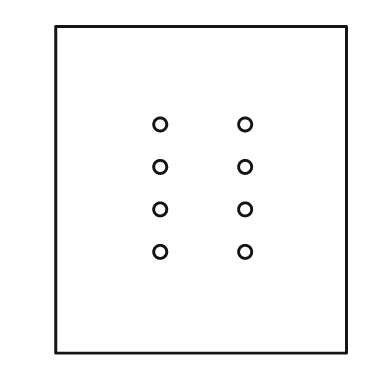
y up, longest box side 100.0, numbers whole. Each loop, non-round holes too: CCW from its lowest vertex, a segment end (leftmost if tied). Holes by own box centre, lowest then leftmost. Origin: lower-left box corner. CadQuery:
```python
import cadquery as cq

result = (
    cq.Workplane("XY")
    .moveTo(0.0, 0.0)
    .lineTo(89.0, 0.0)
    .lineTo(89.0, 100.0)
    .lineTo(0.0, 100.0)
    .close()
    .moveTo(32.0, 31.0)
    .circle(2.0)
    .moveTo(58.0, 31.0)
    .circle(2.0)
    .moveTo(32.0, 44.0)
    .circle(2.0)
    .moveTo(58.0, 44.0)
    .circle(2.0)
    .moveTo(32.0, 57.0)
    .circle(2.0)
    .moveTo(58.0, 57.0)
    .circle(2.0)
    .moveTo(32.0, 70.0)
    .circle(2.0)
    .moveTo(58.0, 70.0)
    .circle(2.0)
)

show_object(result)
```